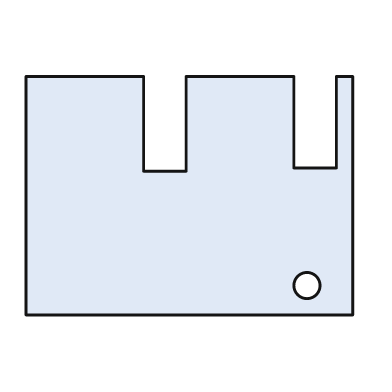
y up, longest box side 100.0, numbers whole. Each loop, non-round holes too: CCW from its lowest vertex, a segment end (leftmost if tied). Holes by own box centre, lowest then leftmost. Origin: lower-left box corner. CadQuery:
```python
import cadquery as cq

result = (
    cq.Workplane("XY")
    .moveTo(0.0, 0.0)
    .lineTo(100.0, 0.0)
    .lineTo(100.0, 73.0)
    .lineTo(95.0, 73.0)
    .lineTo(95.0, 45.0)
    .lineTo(82.0, 45.0)
    .lineTo(82.0, 73.0)
    .lineTo(49.0, 73.0)
    .lineTo(49.0, 44.0)
    .lineTo(36.0, 44.0)
    .lineTo(36.0, 73.0)
    .lineTo(0.0, 73.0)
    .close()
    .moveTo(86.0, 9.0)
    .circle(4.0)
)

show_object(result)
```